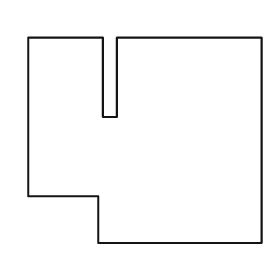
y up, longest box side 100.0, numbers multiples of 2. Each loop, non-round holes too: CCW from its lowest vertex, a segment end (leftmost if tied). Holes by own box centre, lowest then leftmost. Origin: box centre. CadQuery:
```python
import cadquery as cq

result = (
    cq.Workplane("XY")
    .moveTo(-20.0, -44.0)
    .lineTo(50.0, -44.0)
    .lineTo(50.0, 44.0)
    .lineTo(-12.0, 44.0)
    .lineTo(-12.0, 10.0)
    .lineTo(-18.0, 10.0)
    .lineTo(-18.0, 44.0)
    .lineTo(-50.0, 44.0)
    .lineTo(-50.0, -24.0)
    .lineTo(-20.0, -24.0)
    .close()
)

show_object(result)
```